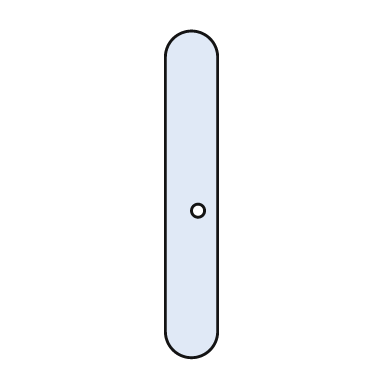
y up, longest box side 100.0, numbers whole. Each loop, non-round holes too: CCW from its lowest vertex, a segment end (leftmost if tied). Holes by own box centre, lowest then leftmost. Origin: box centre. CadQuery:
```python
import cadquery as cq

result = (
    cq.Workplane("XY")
    .moveTo(-8.0, -42.0)
    .threePointArc((0.0, -50.0), (8.0, -42.0))
    .lineTo(8.0, 42.0)
    .threePointArc((0.0, 50.0), (-8.0, 42.0))
    .close()
    .moveTo(2.0, -5.0)
    .circle(2.0)
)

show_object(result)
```